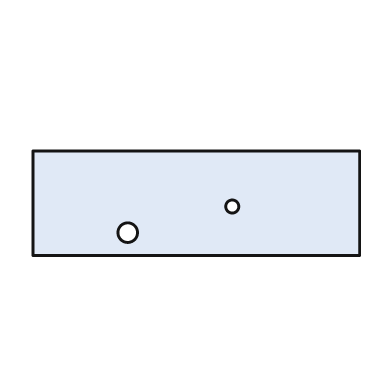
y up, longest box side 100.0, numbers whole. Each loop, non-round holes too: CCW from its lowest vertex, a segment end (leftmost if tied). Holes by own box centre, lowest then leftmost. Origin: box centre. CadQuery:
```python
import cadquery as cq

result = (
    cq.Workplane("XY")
    .moveTo(-50.0, -16.0)
    .lineTo(50.0, -16.0)
    .lineTo(50.0, 16.0)
    .lineTo(-50.0, 16.0)
    .close()
    .moveTo(-21.0, -9.0)
    .circle(3.0)
    .moveTo(11.0, -1.0)
    .circle(2.0)
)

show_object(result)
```